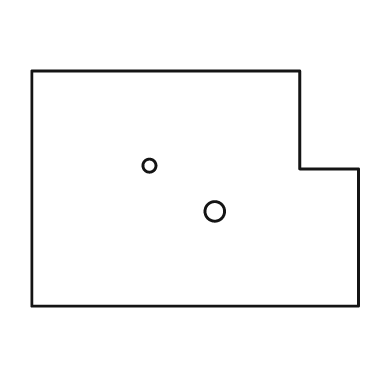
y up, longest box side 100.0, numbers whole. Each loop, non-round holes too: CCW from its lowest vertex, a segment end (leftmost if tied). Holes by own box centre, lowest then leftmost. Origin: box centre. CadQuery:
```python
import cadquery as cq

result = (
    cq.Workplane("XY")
    .moveTo(-50.0, -36.0)
    .lineTo(50.0, -36.0)
    .lineTo(50.0, 6.0)
    .lineTo(32.0, 6.0)
    .lineTo(32.0, 36.0)
    .lineTo(-50.0, 36.0)
    .close()
    .moveTo(6.0, -7.0)
    .circle(3.0)
    .moveTo(-14.0, 7.0)
    .circle(2.0)
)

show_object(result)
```